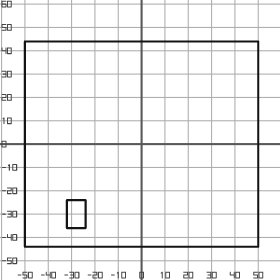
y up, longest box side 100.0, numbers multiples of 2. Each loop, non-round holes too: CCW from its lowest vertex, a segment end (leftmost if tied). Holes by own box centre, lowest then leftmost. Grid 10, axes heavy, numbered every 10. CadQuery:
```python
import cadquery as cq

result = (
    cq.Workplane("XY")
    .moveTo(-50.0, -44.0)
    .lineTo(50.0, -44.0)
    .lineTo(50.0, 44.0)
    .lineTo(-50.0, 44.0)
    .close()
    .moveTo(-32.0, -36.0)
    .lineTo(-24.0, -36.0)
    .lineTo(-24.0, -24.0)
    .lineTo(-32.0, -24.0)
    .close()
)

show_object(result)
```